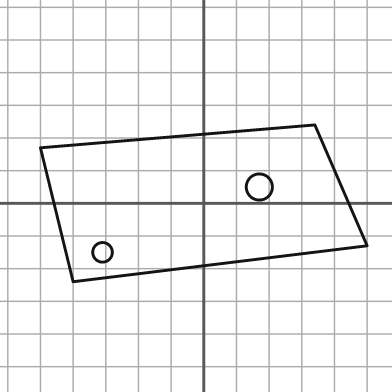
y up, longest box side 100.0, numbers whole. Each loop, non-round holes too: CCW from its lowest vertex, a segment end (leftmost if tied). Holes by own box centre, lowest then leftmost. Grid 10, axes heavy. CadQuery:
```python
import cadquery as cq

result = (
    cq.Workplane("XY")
    .moveTo(-40.0, -24.0)
    .lineTo(50.0, -13.0)
    .lineTo(34.0, 24.0)
    .lineTo(-50.0, 17.0)
    .close()
    .moveTo(-31.0, -15.0)
    .circle(3.0)
    .moveTo(17.0, 5.0)
    .circle(4.0)
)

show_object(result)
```